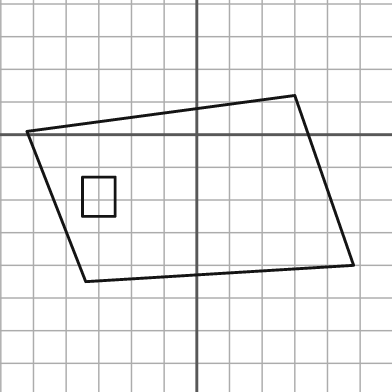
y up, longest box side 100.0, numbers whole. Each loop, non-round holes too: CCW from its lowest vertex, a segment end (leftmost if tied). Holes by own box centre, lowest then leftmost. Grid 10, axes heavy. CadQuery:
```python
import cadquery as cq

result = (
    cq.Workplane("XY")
    .moveTo(-34.0, -45.0)
    .lineTo(48.0, -40.0)
    .lineTo(30.0, 12.0)
    .lineTo(-52.0, 1.0)
    .close()
    .moveTo(-35.0, -25.0)
    .lineTo(-25.0, -25.0)
    .lineTo(-25.0, -13.0)
    .lineTo(-35.0, -13.0)
    .close()
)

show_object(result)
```